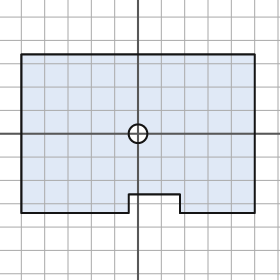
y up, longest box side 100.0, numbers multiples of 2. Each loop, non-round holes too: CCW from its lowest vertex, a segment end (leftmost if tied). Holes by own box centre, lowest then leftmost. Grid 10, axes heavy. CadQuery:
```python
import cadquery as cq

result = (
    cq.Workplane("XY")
    .moveTo(-50.0, -34.0)
    .lineTo(-4.0, -34.0)
    .lineTo(-4.0, -26.0)
    .lineTo(18.0, -26.0)
    .lineTo(18.0, -34.0)
    .lineTo(50.0, -34.0)
    .lineTo(50.0, 34.0)
    .lineTo(-50.0, 34.0)
    .close()
    .moveTo(0.0, 0.0)
    .circle(4.0)
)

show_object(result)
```